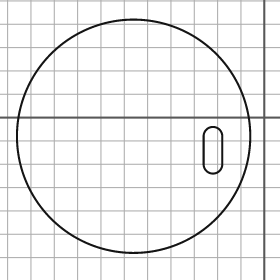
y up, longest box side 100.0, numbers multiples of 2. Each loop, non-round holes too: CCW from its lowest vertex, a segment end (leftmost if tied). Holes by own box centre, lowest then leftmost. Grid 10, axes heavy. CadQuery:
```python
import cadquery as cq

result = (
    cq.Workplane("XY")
    .moveTo(-56.0, -8.0)
    .circle(50.0)
    .moveTo(-26.0, -20.0)
    .threePointArc((-22.0, -24.0), (-18.0, -20.0))
    .lineTo(-18.0, -8.0)
    .threePointArc((-22.0, -4.0), (-26.0, -8.0))
    .close()
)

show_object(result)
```